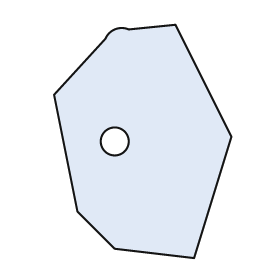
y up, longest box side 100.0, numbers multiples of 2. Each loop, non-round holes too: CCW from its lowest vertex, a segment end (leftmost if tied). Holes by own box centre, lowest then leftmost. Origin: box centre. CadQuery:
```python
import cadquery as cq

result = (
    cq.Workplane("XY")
    .moveTo(22.0, -50.0)
    .lineTo(38.0, 2.0)
    .lineTo(14.0, 50.0)
    .lineTo(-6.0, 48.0)
    .threePointArc((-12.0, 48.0), (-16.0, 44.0))
    .lineTo(-38.0, 20.0)
    .lineTo(-28.0, -30.0)
    .lineTo(-12.0, -46.0)
    .close()
    .moveTo(-12.0, 0.0)
    .circle(6.0)
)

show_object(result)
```